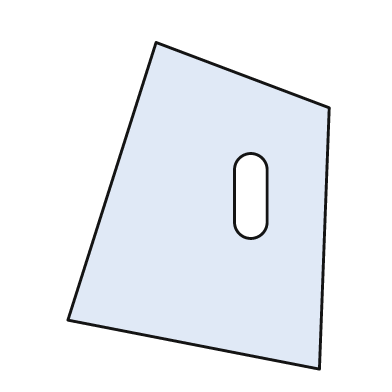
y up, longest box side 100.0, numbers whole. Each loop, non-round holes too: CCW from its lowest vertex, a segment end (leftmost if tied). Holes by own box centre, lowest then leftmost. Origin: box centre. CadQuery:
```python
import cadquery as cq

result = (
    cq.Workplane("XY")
    .moveTo(37.0, -50.0)
    .lineTo(40.0, 30.0)
    .lineTo(-13.0, 50.0)
    .lineTo(-40.0, -35.0)
    .close()
    .moveTo(11.0, -5.0)
    .threePointArc((16.0, -10.0), (21.0, -5.0))
    .lineTo(21.0, 11.0)
    .threePointArc((16.0, 16.0), (11.0, 11.0))
    .close()
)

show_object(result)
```